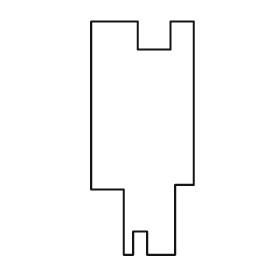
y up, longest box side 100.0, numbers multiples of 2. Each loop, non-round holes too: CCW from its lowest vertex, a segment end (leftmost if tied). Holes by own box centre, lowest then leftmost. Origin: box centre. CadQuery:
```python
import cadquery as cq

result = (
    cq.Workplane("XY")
    .moveTo(-8.0, -50.0)
    .lineTo(-4.0, -50.0)
    .lineTo(-4.0, -40.0)
    .lineTo(2.0, -40.0)
    .lineTo(2.0, -50.0)
    .lineTo(14.0, -50.0)
    .lineTo(14.0, -20.0)
    .lineTo(22.0, -20.0)
    .lineTo(22.0, 50.0)
    .lineTo(12.0, 50.0)
    .lineTo(12.0, 38.0)
    .lineTo(-2.0, 38.0)
    .lineTo(-2.0, 50.0)
    .lineTo(-22.0, 50.0)
    .lineTo(-22.0, -22.0)
    .lineTo(-8.0, -22.0)
    .close()
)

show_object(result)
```